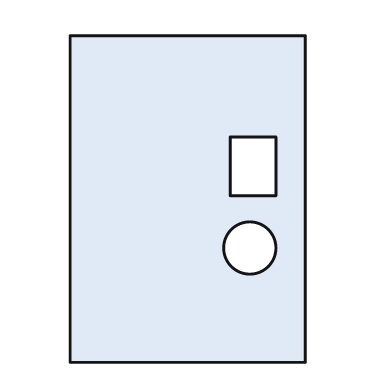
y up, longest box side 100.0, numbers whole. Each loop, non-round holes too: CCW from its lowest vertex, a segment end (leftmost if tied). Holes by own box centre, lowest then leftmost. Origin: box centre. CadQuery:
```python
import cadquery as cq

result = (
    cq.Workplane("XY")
    .moveTo(-36.0, -50.0)
    .lineTo(36.0, -50.0)
    .lineTo(36.0, 50.0)
    .lineTo(-36.0, 50.0)
    .close()
    .moveTo(19.0, -15.0)
    .circle(8.0)
    .moveTo(13.0, 1.0)
    .lineTo(27.0, 1.0)
    .lineTo(27.0, 19.0)
    .lineTo(13.0, 19.0)
    .close()
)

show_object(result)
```